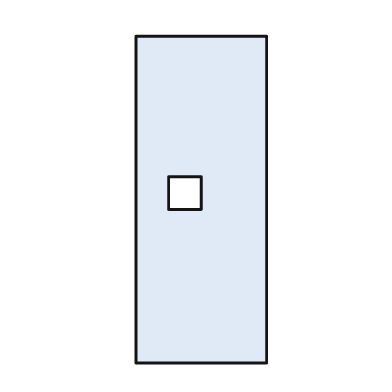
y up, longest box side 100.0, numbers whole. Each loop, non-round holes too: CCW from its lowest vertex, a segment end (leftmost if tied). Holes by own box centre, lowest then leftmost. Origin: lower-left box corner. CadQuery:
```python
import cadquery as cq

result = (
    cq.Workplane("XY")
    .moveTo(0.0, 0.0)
    .lineTo(40.0, 0.0)
    .lineTo(40.0, 100.0)
    .lineTo(0.0, 100.0)
    .close()
    .moveTo(10.0, 47.0)
    .lineTo(20.0, 47.0)
    .lineTo(20.0, 57.0)
    .lineTo(10.0, 57.0)
    .close()
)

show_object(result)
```